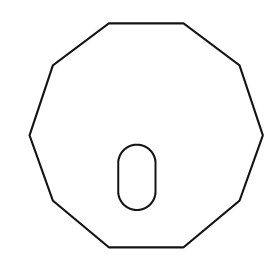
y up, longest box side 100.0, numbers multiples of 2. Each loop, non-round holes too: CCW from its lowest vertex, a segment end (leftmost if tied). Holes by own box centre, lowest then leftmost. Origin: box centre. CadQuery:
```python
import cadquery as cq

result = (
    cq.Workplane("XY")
    .moveTo(-16.0, -48.0)
    .lineTo(16.0, -48.0)
    .lineTo(40.0, -28.0)
    .lineTo(50.0, 0.0)
    .lineTo(40.0, 30.0)
    .lineTo(16.0, 48.0)
    .lineTo(-16.0, 48.0)
    .lineTo(-40.0, 30.0)
    .lineTo(-50.0, 0.0)
    .lineTo(-40.0, -28.0)
    .close()
    .moveTo(-12.0, -24.0)
    .threePointArc((-4.0, -32.0), (4.0, -24.0))
    .lineTo(4.0, -12.0)
    .threePointArc((-4.0, -4.0), (-12.0, -12.0))
    .close()
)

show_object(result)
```